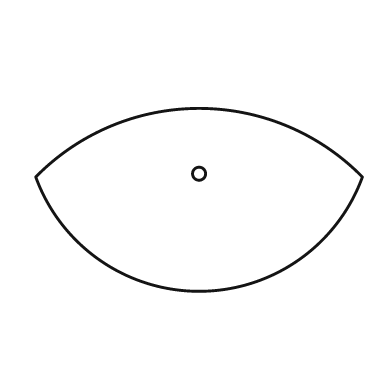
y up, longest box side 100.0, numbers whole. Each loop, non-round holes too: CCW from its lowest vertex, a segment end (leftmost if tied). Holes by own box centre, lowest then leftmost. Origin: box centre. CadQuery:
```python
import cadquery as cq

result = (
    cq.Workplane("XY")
    .moveTo(-50.0, 7.0)
    .threePointArc((0.0, -28.0), (50.0, 7.0))
    .threePointArc((0.0, 28.0), (-50.0, 7.0))
    .close()
    .moveTo(0.0, 8.0)
    .circle(2.0)
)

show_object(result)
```